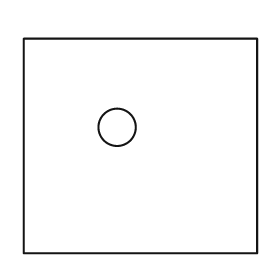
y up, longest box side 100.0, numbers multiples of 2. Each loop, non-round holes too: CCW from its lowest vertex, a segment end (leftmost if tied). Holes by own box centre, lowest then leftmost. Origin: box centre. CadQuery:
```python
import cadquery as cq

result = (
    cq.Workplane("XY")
    .moveTo(-50.0, -46.0)
    .lineTo(50.0, -46.0)
    .lineTo(50.0, 46.0)
    .lineTo(-50.0, 46.0)
    .close()
    .moveTo(-10.0, 8.0)
    .circle(8.0)
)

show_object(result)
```